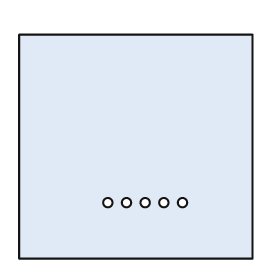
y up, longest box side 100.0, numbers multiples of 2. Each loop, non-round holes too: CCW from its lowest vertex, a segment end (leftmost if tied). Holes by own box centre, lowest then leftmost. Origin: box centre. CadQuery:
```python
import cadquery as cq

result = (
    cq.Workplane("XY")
    .moveTo(-50.0, -48.0)
    .lineTo(50.0, -48.0)
    .lineTo(50.0, 48.0)
    .lineTo(-50.0, 48.0)
    .close()
    .moveTo(-12.0, -24.0)
    .circle(2.0)
    .moveTo(-4.0, -24.0)
    .circle(2.0)
    .moveTo(4.0, -24.0)
    .circle(2.0)
    .moveTo(12.0, -24.0)
    .circle(2.0)
    .moveTo(20.0, -24.0)
    .circle(2.0)
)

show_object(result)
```